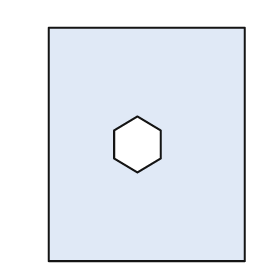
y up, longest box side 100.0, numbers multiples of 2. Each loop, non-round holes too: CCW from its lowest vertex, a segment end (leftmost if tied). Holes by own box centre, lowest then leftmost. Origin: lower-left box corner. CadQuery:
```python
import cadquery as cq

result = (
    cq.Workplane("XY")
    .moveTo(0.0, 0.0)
    .lineTo(84.0, 0.0)
    .lineTo(84.0, 100.0)
    .lineTo(0.0, 100.0)
    .close()
    .moveTo(38.0, 38.0)
    .lineTo(48.0, 44.0)
    .lineTo(48.0, 56.0)
    .lineTo(38.0, 62.0)
    .lineTo(28.0, 56.0)
    .lineTo(28.0, 44.0)
    .close()
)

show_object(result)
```